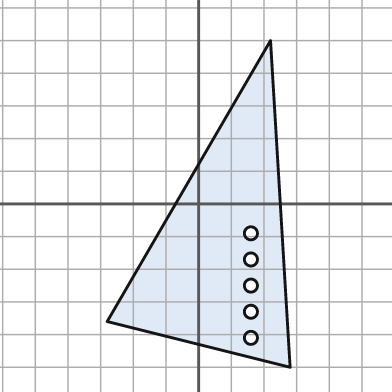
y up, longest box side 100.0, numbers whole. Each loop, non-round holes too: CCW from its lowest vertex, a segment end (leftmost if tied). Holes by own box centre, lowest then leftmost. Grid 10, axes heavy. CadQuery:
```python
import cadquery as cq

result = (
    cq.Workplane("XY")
    .moveTo(28.0, -50.0)
    .lineTo(22.0, 50.0)
    .lineTo(-28.0, -36.0)
    .close()
    .moveTo(16.0, -41.0)
    .circle(2.0)
    .moveTo(16.0, -33.0)
    .circle(2.0)
    .moveTo(16.0, -25.0)
    .circle(2.0)
    .moveTo(16.0, -17.0)
    .circle(2.0)
    .moveTo(16.0, -9.0)
    .circle(2.0)
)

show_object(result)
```